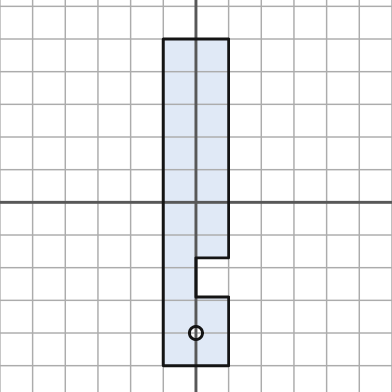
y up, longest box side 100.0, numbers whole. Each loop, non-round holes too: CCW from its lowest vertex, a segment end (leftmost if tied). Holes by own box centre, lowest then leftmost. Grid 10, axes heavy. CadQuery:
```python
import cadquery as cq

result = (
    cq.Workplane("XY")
    .moveTo(-10.0, -50.0)
    .lineTo(10.0, -50.0)
    .lineTo(10.0, -29.0)
    .lineTo(0.0, -29.0)
    .lineTo(0.0, -17.0)
    .lineTo(10.0, -17.0)
    .lineTo(10.0, 50.0)
    .lineTo(-10.0, 50.0)
    .close()
    .moveTo(0.0, -40.0)
    .circle(2.0)
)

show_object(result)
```